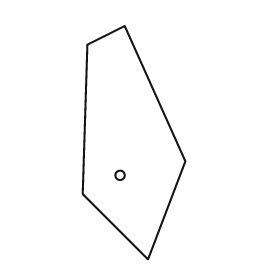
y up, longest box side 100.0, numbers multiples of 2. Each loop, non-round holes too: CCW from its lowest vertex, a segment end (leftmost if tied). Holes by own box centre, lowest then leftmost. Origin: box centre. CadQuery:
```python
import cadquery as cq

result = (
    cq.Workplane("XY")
    .moveTo(6.0, -50.0)
    .lineTo(22.0, -8.0)
    .lineTo(-4.0, 50.0)
    .lineTo(-20.0, 42.0)
    .lineTo(-22.0, -22.0)
    .close()
    .moveTo(-6.0, -14.0)
    .circle(2.0)
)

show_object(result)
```